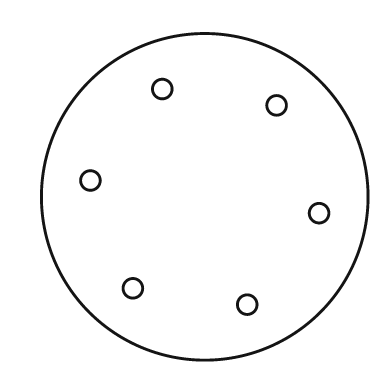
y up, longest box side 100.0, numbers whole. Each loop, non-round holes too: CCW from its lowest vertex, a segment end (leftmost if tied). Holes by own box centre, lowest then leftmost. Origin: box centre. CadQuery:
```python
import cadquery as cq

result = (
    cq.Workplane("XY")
    .moveTo(0.0, 0.0)
    .circle(50.0)
    .moveTo(13.0, -33.0)
    .circle(3.0)
    .moveTo(-22.0, -28.0)
    .circle(3.0)
    .moveTo(35.0, -5.0)
    .circle(3.0)
    .moveTo(-35.0, 5.0)
    .circle(3.0)
    .moveTo(22.0, 28.0)
    .circle(3.0)
    .moveTo(-13.0, 33.0)
    .circle(3.0)
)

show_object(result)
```